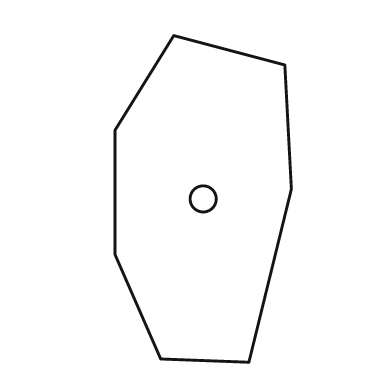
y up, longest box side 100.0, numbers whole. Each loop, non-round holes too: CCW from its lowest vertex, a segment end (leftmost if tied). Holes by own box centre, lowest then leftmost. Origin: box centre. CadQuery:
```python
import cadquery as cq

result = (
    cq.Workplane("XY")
    .moveTo(14.0, -50.0)
    .lineTo(27.0, 3.0)
    .lineTo(25.0, 41.0)
    .lineTo(-9.0, 50.0)
    .lineTo(-27.0, 21.0)
    .lineTo(-27.0, -17.0)
    .lineTo(-13.0, -49.0)
    .close()
    .moveTo(0.0, 0.0)
    .circle(4.0)
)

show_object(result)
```